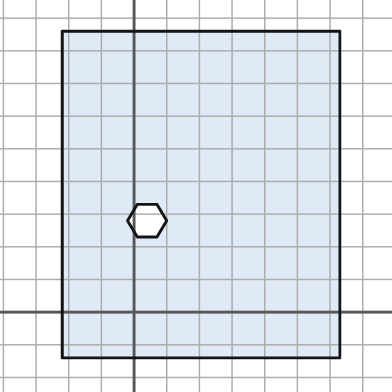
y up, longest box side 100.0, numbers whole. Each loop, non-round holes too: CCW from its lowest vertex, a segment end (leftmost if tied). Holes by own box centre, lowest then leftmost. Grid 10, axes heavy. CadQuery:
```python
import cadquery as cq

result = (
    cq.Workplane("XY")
    .moveTo(-22.0, -14.0)
    .lineTo(63.0, -14.0)
    .lineTo(63.0, 86.0)
    .lineTo(-22.0, 86.0)
    .close()
    .moveTo(1.0, 23.0)
    .lineTo(7.0, 23.0)
    .lineTo(10.0, 28.0)
    .lineTo(7.0, 33.0)
    .lineTo(1.0, 33.0)
    .lineTo(-2.0, 28.0)
    .close()
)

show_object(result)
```